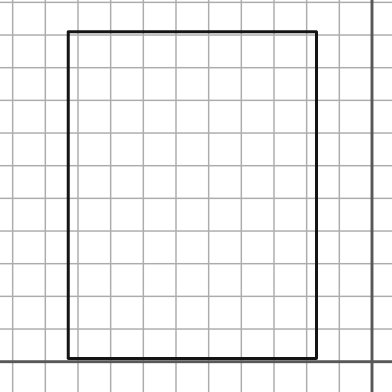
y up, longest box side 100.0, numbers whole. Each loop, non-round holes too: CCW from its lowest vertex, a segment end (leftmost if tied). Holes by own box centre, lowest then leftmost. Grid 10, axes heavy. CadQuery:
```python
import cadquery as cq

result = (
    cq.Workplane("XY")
    .moveTo(-93.0, 1.0)
    .lineTo(-17.0, 1.0)
    .lineTo(-17.0, 101.0)
    .lineTo(-93.0, 101.0)
    .close()
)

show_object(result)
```